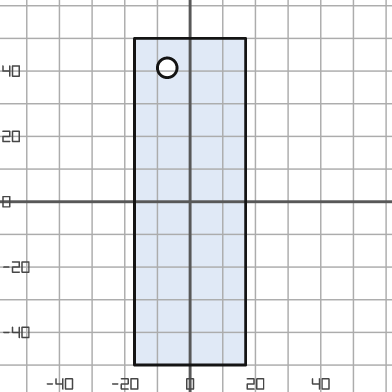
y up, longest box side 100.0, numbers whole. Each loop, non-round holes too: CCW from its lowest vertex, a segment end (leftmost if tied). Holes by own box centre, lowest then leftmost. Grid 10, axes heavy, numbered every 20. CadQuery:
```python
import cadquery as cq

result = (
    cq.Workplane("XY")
    .moveTo(-17.0, -50.0)
    .lineTo(17.0, -50.0)
    .lineTo(17.0, 50.0)
    .lineTo(-17.0, 50.0)
    .close()
    .moveTo(-7.0, 41.0)
    .circle(3.0)
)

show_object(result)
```